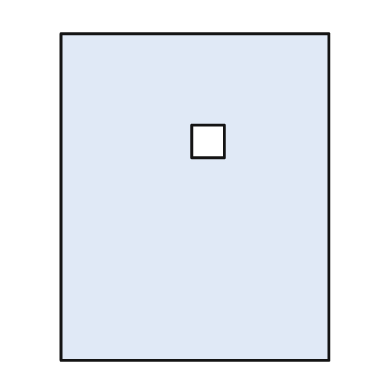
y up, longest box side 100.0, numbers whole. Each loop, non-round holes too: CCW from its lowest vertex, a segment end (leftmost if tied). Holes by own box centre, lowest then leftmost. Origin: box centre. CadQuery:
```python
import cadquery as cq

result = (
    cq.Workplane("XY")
    .moveTo(-41.0, -50.0)
    .lineTo(41.0, -50.0)
    .lineTo(41.0, 50.0)
    .lineTo(-41.0, 50.0)
    .close()
    .moveTo(-1.0, 12.0)
    .lineTo(9.0, 12.0)
    .lineTo(9.0, 22.0)
    .lineTo(-1.0, 22.0)
    .close()
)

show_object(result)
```